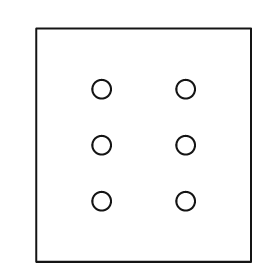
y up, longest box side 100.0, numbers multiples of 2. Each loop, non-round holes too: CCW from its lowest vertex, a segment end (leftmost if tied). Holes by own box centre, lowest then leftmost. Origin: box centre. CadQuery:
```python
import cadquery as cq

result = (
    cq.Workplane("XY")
    .moveTo(-46.0, -50.0)
    .lineTo(46.0, -50.0)
    .lineTo(46.0, 50.0)
    .lineTo(-46.0, 50.0)
    .close()
    .moveTo(-18.0, -24.0)
    .circle(4.0)
    .moveTo(18.0, -24.0)
    .circle(4.0)
    .moveTo(-18.0, 0.0)
    .circle(4.0)
    .moveTo(18.0, 0.0)
    .circle(4.0)
    .moveTo(-18.0, 24.0)
    .circle(4.0)
    .moveTo(18.0, 24.0)
    .circle(4.0)
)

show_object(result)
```